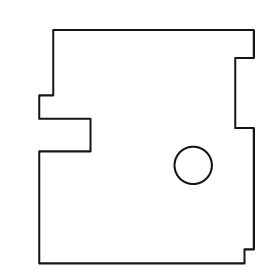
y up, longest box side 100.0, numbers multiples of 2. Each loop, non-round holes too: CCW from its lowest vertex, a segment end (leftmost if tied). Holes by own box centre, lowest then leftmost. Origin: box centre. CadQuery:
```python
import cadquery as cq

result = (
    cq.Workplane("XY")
    .moveTo(-46.0, -50.0)
    .lineTo(42.0, -50.0)
    .lineTo(42.0, -44.0)
    .lineTo(46.0, -44.0)
    .lineTo(46.0, 8.0)
    .lineTo(38.0, 8.0)
    .lineTo(38.0, 38.0)
    .lineTo(46.0, 38.0)
    .lineTo(46.0, 50.0)
    .lineTo(-40.0, 50.0)
    .lineTo(-40.0, 22.0)
    .lineTo(-46.0, 22.0)
    .lineTo(-46.0, 12.0)
    .lineTo(-24.0, 12.0)
    .lineTo(-24.0, -2.0)
    .lineTo(-46.0, -2.0)
    .close()
    .moveTo(20.0, -8.0)
    .circle(8.0)
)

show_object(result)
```